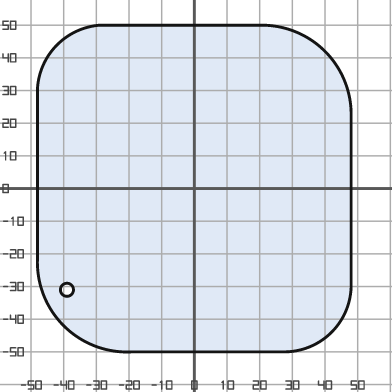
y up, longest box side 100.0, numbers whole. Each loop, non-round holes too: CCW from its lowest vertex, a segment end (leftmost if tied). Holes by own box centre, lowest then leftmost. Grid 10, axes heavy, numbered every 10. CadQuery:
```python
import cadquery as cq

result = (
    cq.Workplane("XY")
    .moveTo(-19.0, -50.0)
    .lineTo(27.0, -50.0)
    .threePointArc((42.0, -44.0), (48.0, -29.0))
    .lineTo(48.0, 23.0)
    .threePointArc((40.0, 42.0), (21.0, 50.0))
    .lineTo(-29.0, 50.0)
    .threePointArc((-42.0, 44.0), (-48.0, 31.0))
    .lineTo(-48.0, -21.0)
    .threePointArc((-40.0, -42.0), (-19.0, -50.0))
    .close()
    .moveTo(-39.0, -31.0)
    .circle(2.0)
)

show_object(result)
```